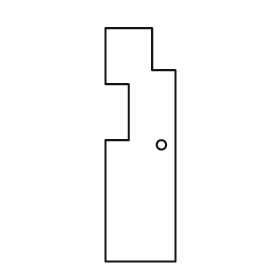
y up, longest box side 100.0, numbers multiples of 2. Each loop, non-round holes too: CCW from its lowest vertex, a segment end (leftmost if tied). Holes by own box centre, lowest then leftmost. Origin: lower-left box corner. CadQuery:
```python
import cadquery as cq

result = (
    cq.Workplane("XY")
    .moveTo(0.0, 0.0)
    .lineTo(30.0, 0.0)
    .lineTo(30.0, 82.0)
    .lineTo(20.0, 82.0)
    .lineTo(20.0, 100.0)
    .lineTo(0.0, 100.0)
    .lineTo(0.0, 76.0)
    .lineTo(10.0, 76.0)
    .lineTo(10.0, 52.0)
    .lineTo(0.0, 52.0)
    .close()
    .moveTo(24.0, 50.0)
    .circle(2.0)
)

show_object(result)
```